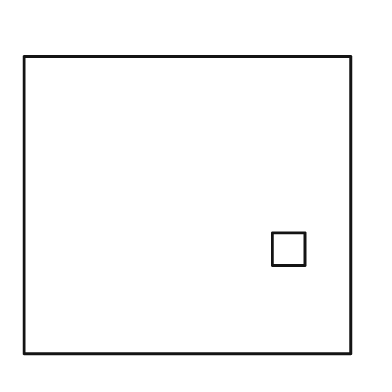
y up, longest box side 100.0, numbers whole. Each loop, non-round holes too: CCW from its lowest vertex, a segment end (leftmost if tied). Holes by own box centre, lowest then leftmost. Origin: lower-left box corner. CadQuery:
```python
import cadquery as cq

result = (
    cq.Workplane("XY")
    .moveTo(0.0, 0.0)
    .lineTo(100.0, 0.0)
    .lineTo(100.0, 91.0)
    .lineTo(0.0, 91.0)
    .close()
    .moveTo(76.0, 27.0)
    .lineTo(86.0, 27.0)
    .lineTo(86.0, 37.0)
    .lineTo(76.0, 37.0)
    .close()
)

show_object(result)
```